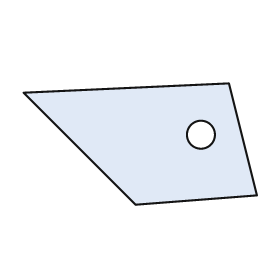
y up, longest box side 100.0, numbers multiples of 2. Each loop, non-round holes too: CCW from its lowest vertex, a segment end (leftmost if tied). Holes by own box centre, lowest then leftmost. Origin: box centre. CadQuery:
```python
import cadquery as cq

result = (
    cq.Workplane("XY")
    .moveTo(-2.0, -26.0)
    .lineTo(50.0, -22.0)
    .lineTo(38.0, 26.0)
    .lineTo(-50.0, 22.0)
    .close()
    .moveTo(26.0, 4.0)
    .circle(6.0)
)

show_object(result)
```